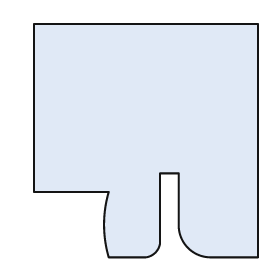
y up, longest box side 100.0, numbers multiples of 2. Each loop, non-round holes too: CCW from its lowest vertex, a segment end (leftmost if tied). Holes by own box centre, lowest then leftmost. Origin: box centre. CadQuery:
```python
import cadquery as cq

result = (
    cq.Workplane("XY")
    .moveTo(-16.0, -50.0)
    .lineTo(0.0, -50.0)
    .threePointArc((4.0, -48.0), (6.0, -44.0))
    .lineTo(6.0, -14.0)
    .lineTo(14.0, -14.0)
    .lineTo(14.0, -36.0)
    .threePointArc((18.0, -46.0), (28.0, -50.0))
    .lineTo(48.0, -50.0)
    .lineTo(48.0, 50.0)
    .lineTo(-48.0, 50.0)
    .lineTo(-48.0, -22.0)
    .lineTo(-16.0, -22.0)
    .threePointArc((-18.0, -36.0), (-16.0, -50.0))
    .close()
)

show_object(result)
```